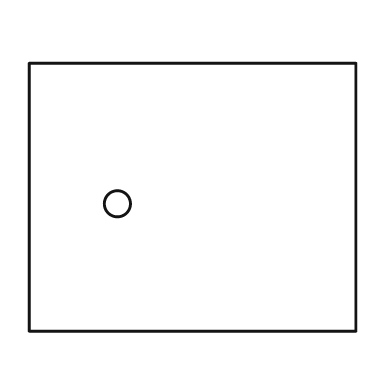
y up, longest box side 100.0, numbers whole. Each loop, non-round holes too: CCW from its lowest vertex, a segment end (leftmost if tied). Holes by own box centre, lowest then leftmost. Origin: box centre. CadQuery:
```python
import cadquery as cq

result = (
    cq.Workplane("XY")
    .moveTo(-50.0, -41.0)
    .lineTo(50.0, -41.0)
    .lineTo(50.0, 41.0)
    .lineTo(-50.0, 41.0)
    .close()
    .moveTo(-23.0, -2.0)
    .circle(4.0)
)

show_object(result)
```